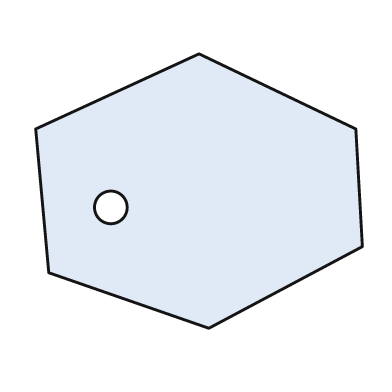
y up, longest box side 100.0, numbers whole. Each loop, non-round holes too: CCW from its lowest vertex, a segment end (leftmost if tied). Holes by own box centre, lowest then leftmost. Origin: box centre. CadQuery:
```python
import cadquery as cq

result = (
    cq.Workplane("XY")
    .moveTo(3.0, -42.0)
    .lineTo(50.0, -17.0)
    .lineTo(48.0, 19.0)
    .lineTo(0.0, 42.0)
    .lineTo(-50.0, 19.0)
    .lineTo(-46.0, -25.0)
    .close()
    .moveTo(-27.0, -5.0)
    .circle(5.0)
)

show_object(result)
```